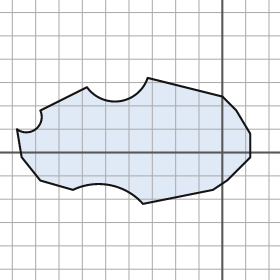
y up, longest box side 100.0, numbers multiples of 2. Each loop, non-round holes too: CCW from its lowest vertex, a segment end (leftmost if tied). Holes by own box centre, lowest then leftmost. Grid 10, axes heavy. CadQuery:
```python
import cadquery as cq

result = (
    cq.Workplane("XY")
    .moveTo(-34.0, -22.0)
    .lineTo(-4.0, -16.0)
    .lineTo(2.0, -12.0)
    .lineTo(12.0, -2.0)
    .lineTo(12.0, 8.0)
    .lineTo(6.0, 18.0)
    .lineTo(0.0, 24.0)
    .lineTo(-32.0, 32.0)
    .threePointArc((-44.0, 22.0), (-58.0, 28.0))
    .lineTo(-78.0, 18.0)
    .threePointArc((-80.0, 10.0), (-88.0, 10.0))
    .lineTo(-86.0, -2.0)
    .lineTo(-78.0, -12.0)
    .lineTo(-64.0, -16.0)
    .threePointArc((-48.0, -14.0), (-34.0, -22.0))
    .close()
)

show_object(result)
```